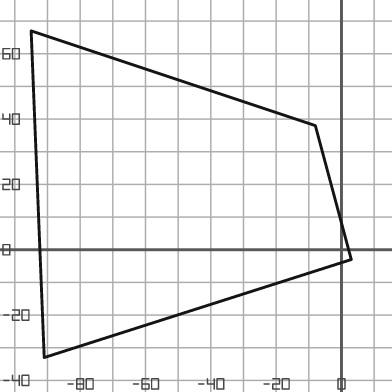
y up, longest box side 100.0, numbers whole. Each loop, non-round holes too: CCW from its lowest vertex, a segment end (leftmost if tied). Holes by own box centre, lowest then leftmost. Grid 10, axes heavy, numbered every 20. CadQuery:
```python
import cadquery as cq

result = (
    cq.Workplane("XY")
    .moveTo(-91.0, -33.0)
    .lineTo(3.0, -3.0)
    .lineTo(-8.0, 38.0)
    .lineTo(-95.0, 67.0)
    .close()
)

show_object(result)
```